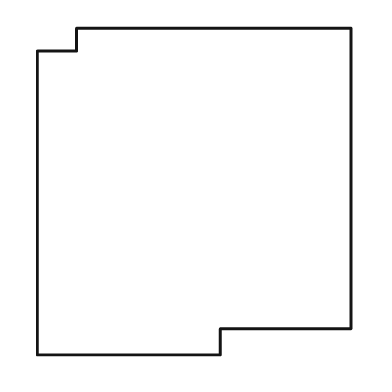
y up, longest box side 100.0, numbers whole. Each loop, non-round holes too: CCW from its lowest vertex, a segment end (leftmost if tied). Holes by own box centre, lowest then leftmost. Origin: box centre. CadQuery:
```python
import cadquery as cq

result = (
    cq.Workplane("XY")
    .moveTo(-48.0, -50.0)
    .lineTo(8.0, -50.0)
    .lineTo(8.0, -42.0)
    .lineTo(48.0, -42.0)
    .lineTo(48.0, 50.0)
    .lineTo(-36.0, 50.0)
    .lineTo(-36.0, 43.0)
    .lineTo(-48.0, 43.0)
    .close()
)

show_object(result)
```